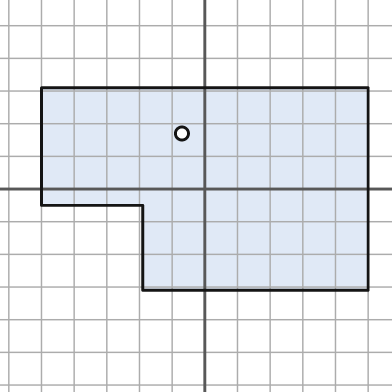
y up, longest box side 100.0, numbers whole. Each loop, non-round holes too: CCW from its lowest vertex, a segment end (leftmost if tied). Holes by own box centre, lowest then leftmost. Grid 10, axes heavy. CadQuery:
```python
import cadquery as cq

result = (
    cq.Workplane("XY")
    .moveTo(-19.0, -31.0)
    .lineTo(50.0, -31.0)
    .lineTo(50.0, 31.0)
    .lineTo(-50.0, 31.0)
    .lineTo(-50.0, -5.0)
    .lineTo(-19.0, -5.0)
    .close()
    .moveTo(-7.0, 17.0)
    .circle(2.0)
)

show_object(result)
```